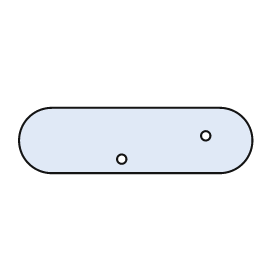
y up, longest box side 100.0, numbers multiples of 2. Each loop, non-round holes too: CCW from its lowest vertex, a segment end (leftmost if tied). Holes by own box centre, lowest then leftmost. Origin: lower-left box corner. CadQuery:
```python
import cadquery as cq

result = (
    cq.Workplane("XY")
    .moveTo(14.0, 0.0)
    .lineTo(86.0, 0.0)
    .threePointArc((100.0, 14.0), (86.0, 28.0))
    .lineTo(14.0, 28.0)
    .threePointArc((0.0, 14.0), (14.0, 0.0))
    .close()
    .moveTo(44.0, 6.0)
    .circle(2.0)
    .moveTo(80.0, 16.0)
    .circle(2.0)
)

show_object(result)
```